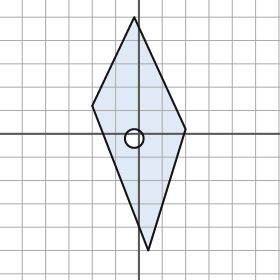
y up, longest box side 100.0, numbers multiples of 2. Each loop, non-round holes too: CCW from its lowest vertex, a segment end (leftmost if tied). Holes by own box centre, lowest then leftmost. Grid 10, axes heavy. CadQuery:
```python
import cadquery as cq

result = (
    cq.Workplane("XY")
    .moveTo(4.0, -50.0)
    .lineTo(20.0, 2.0)
    .lineTo(-2.0, 50.0)
    .lineTo(-20.0, 12.0)
    .close()
    .moveTo(-2.0, -2.0)
    .circle(4.0)
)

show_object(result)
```